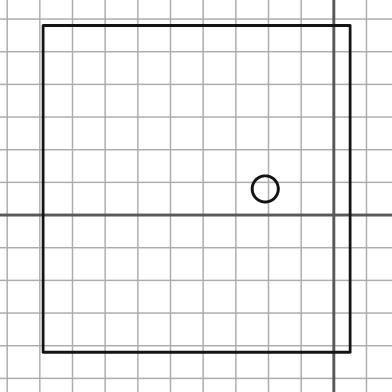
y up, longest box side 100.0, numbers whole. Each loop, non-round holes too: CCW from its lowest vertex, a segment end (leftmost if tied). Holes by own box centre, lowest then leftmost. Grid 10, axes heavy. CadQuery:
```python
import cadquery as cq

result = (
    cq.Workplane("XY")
    .moveTo(-89.0, -42.0)
    .lineTo(5.0, -42.0)
    .lineTo(5.0, 58.0)
    .lineTo(-89.0, 58.0)
    .close()
    .moveTo(-21.0, 8.0)
    .circle(4.0)
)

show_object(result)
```